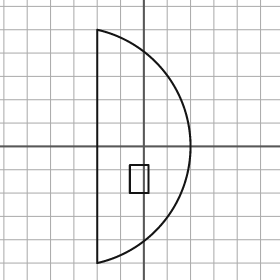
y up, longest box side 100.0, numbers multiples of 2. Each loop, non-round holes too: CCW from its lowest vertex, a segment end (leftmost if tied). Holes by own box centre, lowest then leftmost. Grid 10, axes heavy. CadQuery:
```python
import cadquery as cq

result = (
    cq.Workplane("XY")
    .moveTo(-20.0, -50.0)
    .threePointArc((20.0, 0.0), (-20.0, 50.0))
    .close()
    .moveTo(-6.0, -20.0)
    .lineTo(2.0, -20.0)
    .lineTo(2.0, -8.0)
    .lineTo(-6.0, -8.0)
    .close()
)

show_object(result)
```